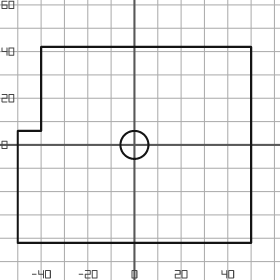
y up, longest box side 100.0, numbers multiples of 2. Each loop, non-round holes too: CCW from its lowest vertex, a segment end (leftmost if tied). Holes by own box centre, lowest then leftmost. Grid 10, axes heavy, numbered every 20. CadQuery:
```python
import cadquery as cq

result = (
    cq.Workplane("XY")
    .moveTo(-50.0, -42.0)
    .lineTo(50.0, -42.0)
    .lineTo(50.0, 42.0)
    .lineTo(-40.0, 42.0)
    .lineTo(-40.0, 6.0)
    .lineTo(-50.0, 6.0)
    .close()
    .moveTo(0.0, 0.0)
    .circle(6.0)
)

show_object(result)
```